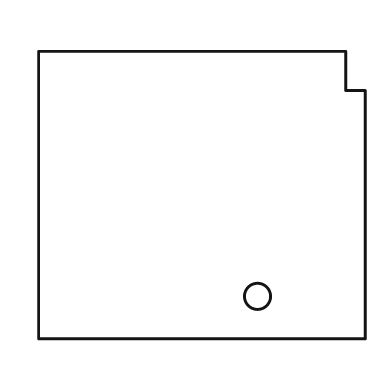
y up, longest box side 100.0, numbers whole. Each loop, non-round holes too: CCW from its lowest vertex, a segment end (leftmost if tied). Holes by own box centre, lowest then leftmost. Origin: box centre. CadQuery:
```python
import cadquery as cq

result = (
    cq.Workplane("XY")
    .moveTo(-50.0, -44.0)
    .lineTo(50.0, -44.0)
    .lineTo(50.0, 32.0)
    .lineTo(44.0, 32.0)
    .lineTo(44.0, 44.0)
    .lineTo(-50.0, 44.0)
    .close()
    .moveTo(17.0, -31.0)
    .circle(4.0)
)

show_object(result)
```